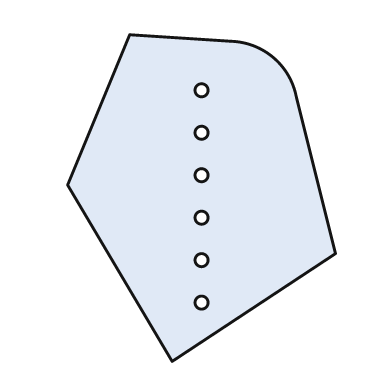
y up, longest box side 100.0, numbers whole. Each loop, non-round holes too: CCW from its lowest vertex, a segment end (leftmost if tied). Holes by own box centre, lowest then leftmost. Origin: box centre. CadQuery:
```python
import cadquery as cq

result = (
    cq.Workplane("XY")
    .moveTo(-9.0, -50.0)
    .lineTo(41.0, -17.0)
    .lineTo(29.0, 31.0)
    .threePointArc((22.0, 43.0), (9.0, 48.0))
    .lineTo(-22.0, 50.0)
    .lineTo(-41.0, 4.0)
    .close()
    .moveTo(0.0, -32.0)
    .circle(2.0)
    .moveTo(0.0, -19.0)
    .circle(2.0)
    .moveTo(0.0, -6.0)
    .circle(2.0)
    .moveTo(0.0, 7.0)
    .circle(2.0)
    .moveTo(0.0, 20.0)
    .circle(2.0)
    .moveTo(0.0, 33.0)
    .circle(2.0)
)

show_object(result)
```